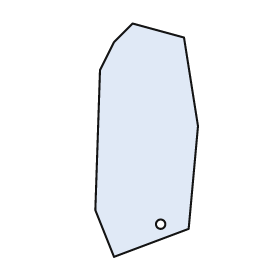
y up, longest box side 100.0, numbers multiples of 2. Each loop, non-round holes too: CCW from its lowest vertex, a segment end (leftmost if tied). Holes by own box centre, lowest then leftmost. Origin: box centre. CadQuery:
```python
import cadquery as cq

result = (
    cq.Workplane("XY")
    .moveTo(-14.0, -50.0)
    .lineTo(18.0, -38.0)
    .lineTo(22.0, 6.0)
    .lineTo(16.0, 44.0)
    .lineTo(-6.0, 50.0)
    .lineTo(-14.0, 42.0)
    .lineTo(-20.0, 30.0)
    .lineTo(-22.0, -30.0)
    .close()
    .moveTo(6.0, -36.0)
    .circle(2.0)
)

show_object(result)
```